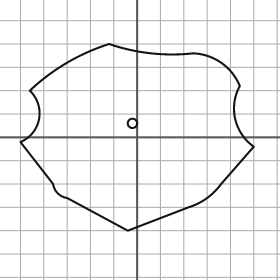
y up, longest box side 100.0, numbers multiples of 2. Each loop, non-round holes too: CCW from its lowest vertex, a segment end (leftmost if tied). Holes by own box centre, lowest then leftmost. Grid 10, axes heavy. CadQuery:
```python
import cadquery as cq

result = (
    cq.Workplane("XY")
    .moveTo(-4.0, -40.0)
    .lineTo(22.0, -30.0)
    .threePointArc((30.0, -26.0), (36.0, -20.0))
    .lineTo(50.0, -4.0)
    .threePointArc((42.0, 8.0), (44.0, 22.0))
    .threePointArc((36.0, 32.0), (24.0, 36.0))
    .threePointArc((6.0, 36.0), (-12.0, 40.0))
    .threePointArc((-30.0, 32.0), (-46.0, 20.0))
    .threePointArc((-42.0, 8.0), (-50.0, -2.0))
    .lineTo(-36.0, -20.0)
    .threePointArc((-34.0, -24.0), (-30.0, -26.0))
    .close()
    .moveTo(-2.0, 6.0)
    .circle(2.0)
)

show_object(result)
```